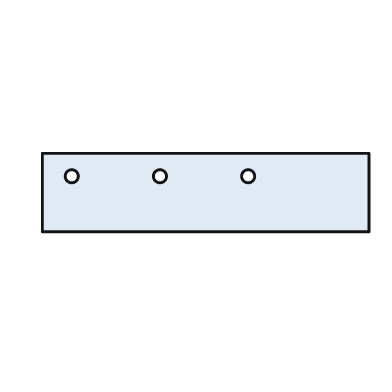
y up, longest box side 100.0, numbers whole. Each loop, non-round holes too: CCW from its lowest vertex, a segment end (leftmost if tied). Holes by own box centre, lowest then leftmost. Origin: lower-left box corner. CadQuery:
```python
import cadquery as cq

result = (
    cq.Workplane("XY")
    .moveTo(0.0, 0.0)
    .lineTo(100.0, 0.0)
    .lineTo(100.0, 24.0)
    .lineTo(0.0, 24.0)
    .close()
    .moveTo(9.0, 17.0)
    .circle(2.0)
    .moveTo(36.0, 17.0)
    .circle(2.0)
    .moveTo(63.0, 17.0)
    .circle(2.0)
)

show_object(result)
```